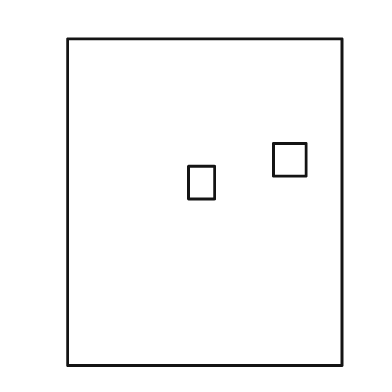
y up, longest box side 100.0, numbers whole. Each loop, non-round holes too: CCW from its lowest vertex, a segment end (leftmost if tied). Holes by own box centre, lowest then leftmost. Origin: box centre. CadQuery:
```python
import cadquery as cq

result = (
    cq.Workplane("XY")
    .moveTo(-42.0, -50.0)
    .lineTo(42.0, -50.0)
    .lineTo(42.0, 50.0)
    .lineTo(-42.0, 50.0)
    .close()
    .moveTo(-5.0, 1.0)
    .lineTo(3.0, 1.0)
    .lineTo(3.0, 11.0)
    .lineTo(-5.0, 11.0)
    .close()
    .moveTo(21.0, 8.0)
    .lineTo(31.0, 8.0)
    .lineTo(31.0, 18.0)
    .lineTo(21.0, 18.0)
    .close()
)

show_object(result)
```